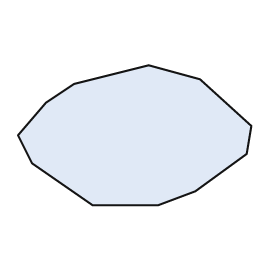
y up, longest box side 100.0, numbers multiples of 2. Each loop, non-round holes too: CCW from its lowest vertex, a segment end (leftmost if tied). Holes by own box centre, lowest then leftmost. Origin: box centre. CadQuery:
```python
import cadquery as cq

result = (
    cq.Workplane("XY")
    .moveTo(-18.0, -30.0)
    .lineTo(10.0, -30.0)
    .lineTo(26.0, -24.0)
    .lineTo(48.0, -8.0)
    .lineTo(50.0, 4.0)
    .lineTo(28.0, 24.0)
    .lineTo(6.0, 30.0)
    .lineTo(-26.0, 22.0)
    .lineTo(-38.0, 14.0)
    .lineTo(-50.0, 0.0)
    .lineTo(-44.0, -12.0)
    .close()
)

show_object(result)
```